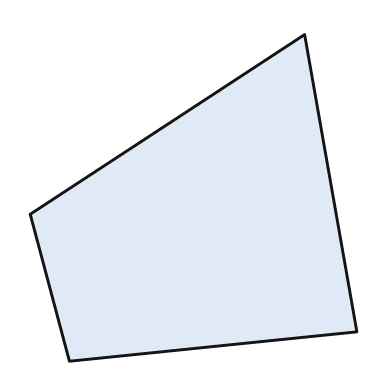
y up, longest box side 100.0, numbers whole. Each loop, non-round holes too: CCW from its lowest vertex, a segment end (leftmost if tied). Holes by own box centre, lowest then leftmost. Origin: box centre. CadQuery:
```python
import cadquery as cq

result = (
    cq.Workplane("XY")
    .moveTo(-38.0, -50.0)
    .lineTo(50.0, -41.0)
    .lineTo(34.0, 50.0)
    .lineTo(-50.0, -5.0)
    .close()
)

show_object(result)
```